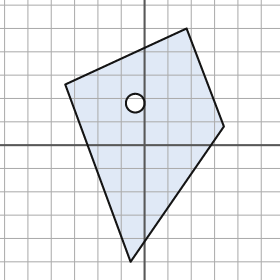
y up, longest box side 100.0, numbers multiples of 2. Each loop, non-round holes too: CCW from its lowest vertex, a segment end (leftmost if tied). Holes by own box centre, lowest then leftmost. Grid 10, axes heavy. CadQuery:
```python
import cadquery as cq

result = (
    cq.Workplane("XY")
    .moveTo(-6.0, -50.0)
    .lineTo(34.0, 8.0)
    .lineTo(18.0, 50.0)
    .lineTo(-34.0, 26.0)
    .close()
    .moveTo(-4.0, 18.0)
    .circle(4.0)
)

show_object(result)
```